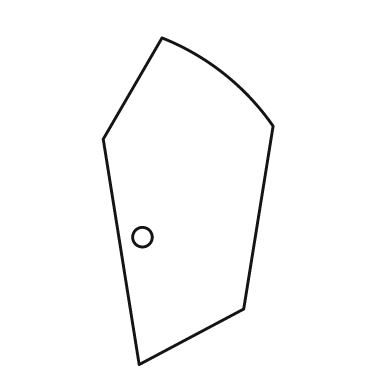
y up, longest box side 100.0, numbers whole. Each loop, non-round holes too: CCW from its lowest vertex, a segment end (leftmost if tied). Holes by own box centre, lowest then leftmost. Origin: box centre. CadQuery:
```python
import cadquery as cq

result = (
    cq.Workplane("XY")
    .moveTo(-15.0, -50.0)
    .lineTo(17.0, -33.0)
    .lineTo(26.0, 23.0)
    .threePointArc((11.0, 39.0), (-8.0, 50.0))
    .lineTo(-26.0, 19.0)
    .close()
    .moveTo(-14.0, -11.0)
    .circle(3.0)
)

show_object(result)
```